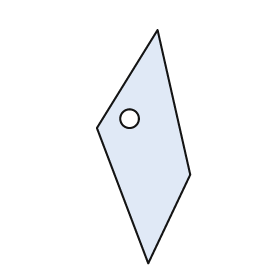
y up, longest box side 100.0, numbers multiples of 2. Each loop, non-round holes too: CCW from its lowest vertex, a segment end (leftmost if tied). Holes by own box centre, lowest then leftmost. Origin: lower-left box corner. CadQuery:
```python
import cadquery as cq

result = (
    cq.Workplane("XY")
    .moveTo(22.0, 0.0)
    .lineTo(40.0, 38.0)
    .lineTo(26.0, 100.0)
    .lineTo(0.0, 58.0)
    .close()
    .moveTo(14.0, 62.0)
    .circle(4.0)
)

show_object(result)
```